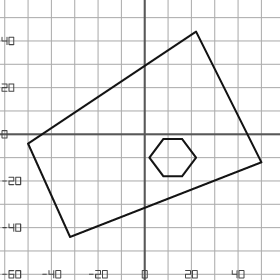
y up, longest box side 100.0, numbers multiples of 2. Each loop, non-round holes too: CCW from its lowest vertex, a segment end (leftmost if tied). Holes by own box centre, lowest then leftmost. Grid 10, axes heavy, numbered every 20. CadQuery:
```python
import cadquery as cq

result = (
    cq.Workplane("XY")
    .moveTo(-32.0, -44.0)
    .lineTo(50.0, -12.0)
    .lineTo(22.0, 44.0)
    .lineTo(-50.0, -4.0)
    .close()
    .moveTo(8.0, -18.0)
    .lineTo(16.0, -18.0)
    .lineTo(22.0, -10.0)
    .lineTo(16.0, -2.0)
    .lineTo(8.0, -2.0)
    .lineTo(2.0, -10.0)
    .close()
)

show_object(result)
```